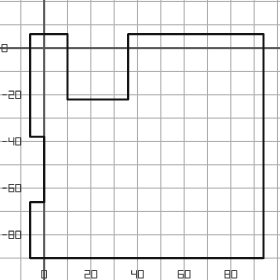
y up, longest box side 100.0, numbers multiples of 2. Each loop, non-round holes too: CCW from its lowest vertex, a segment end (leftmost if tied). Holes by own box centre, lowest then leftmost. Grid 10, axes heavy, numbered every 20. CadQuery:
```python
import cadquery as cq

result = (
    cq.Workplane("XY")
    .moveTo(-6.0, -90.0)
    .lineTo(94.0, -90.0)
    .lineTo(94.0, 6.0)
    .lineTo(36.0, 6.0)
    .lineTo(36.0, -22.0)
    .lineTo(10.0, -22.0)
    .lineTo(10.0, 6.0)
    .lineTo(-6.0, 6.0)
    .lineTo(-6.0, -38.0)
    .lineTo(0.0, -38.0)
    .lineTo(0.0, -66.0)
    .lineTo(-6.0, -66.0)
    .close()
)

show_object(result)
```